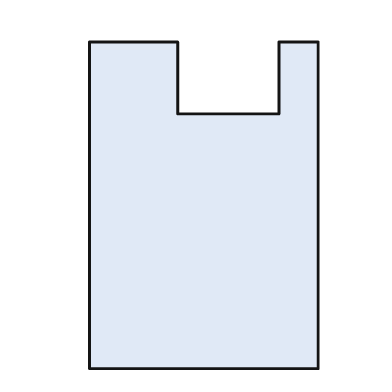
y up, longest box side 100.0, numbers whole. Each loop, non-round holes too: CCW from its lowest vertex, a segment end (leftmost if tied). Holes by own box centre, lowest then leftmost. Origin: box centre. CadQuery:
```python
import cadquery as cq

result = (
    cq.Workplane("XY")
    .moveTo(-35.0, -50.0)
    .lineTo(35.0, -50.0)
    .lineTo(35.0, 50.0)
    .lineTo(23.0, 50.0)
    .lineTo(23.0, 28.0)
    .lineTo(-8.0, 28.0)
    .lineTo(-8.0, 50.0)
    .lineTo(-35.0, 50.0)
    .close()
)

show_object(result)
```